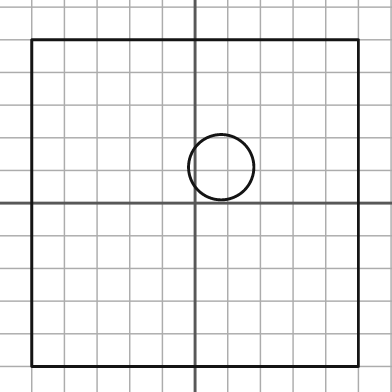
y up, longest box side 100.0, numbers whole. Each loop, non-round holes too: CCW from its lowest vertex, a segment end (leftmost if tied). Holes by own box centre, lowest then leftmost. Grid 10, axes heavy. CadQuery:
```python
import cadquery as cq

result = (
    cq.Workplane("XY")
    .moveTo(-50.0, -50.0)
    .lineTo(50.0, -50.0)
    .lineTo(50.0, 50.0)
    .lineTo(-50.0, 50.0)
    .close()
    .moveTo(8.0, 11.0)
    .circle(10.0)
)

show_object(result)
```